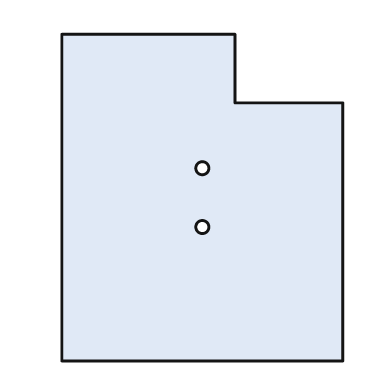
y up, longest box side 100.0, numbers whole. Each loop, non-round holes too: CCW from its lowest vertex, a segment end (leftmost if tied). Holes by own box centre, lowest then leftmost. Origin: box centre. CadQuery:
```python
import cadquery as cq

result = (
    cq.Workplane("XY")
    .moveTo(-43.0, -50.0)
    .lineTo(43.0, -50.0)
    .lineTo(43.0, 29.0)
    .lineTo(10.0, 29.0)
    .lineTo(10.0, 50.0)
    .lineTo(-43.0, 50.0)
    .close()
    .moveTo(0.0, -9.0)
    .circle(2.0)
    .moveTo(0.0, 9.0)
    .circle(2.0)
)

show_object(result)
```